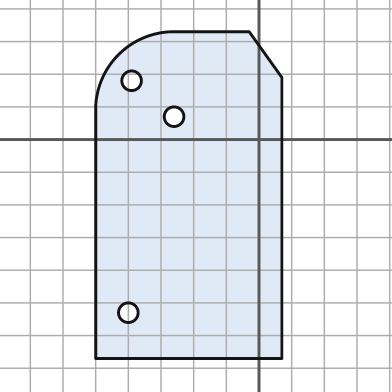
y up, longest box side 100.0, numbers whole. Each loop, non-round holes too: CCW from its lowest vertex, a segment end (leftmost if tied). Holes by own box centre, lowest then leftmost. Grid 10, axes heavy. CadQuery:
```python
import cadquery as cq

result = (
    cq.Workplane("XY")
    .moveTo(-50.0, -67.0)
    .lineTo(7.0, -67.0)
    .lineTo(7.0, 19.0)
    .lineTo(-3.0, 33.0)
    .lineTo(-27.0, 33.0)
    .threePointArc((-43.0, 26.0), (-50.0, 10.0))
    .close()
    .moveTo(-40.0, -53.0)
    .circle(3.0)
    .moveTo(-26.0, 7.0)
    .circle(3.0)
    .moveTo(-39.0, 18.0)
    .circle(3.0)
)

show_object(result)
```